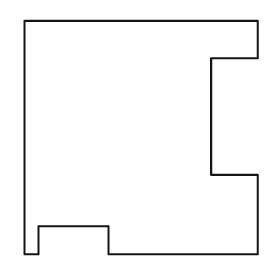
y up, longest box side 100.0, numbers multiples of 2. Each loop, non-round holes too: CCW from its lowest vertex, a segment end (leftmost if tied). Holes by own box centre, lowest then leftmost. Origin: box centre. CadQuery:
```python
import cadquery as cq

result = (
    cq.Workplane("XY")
    .moveTo(-50.0, -50.0)
    .lineTo(-44.0, -50.0)
    .lineTo(-44.0, -38.0)
    .lineTo(-14.0, -38.0)
    .lineTo(-14.0, -50.0)
    .lineTo(50.0, -50.0)
    .lineTo(50.0, -16.0)
    .lineTo(30.0, -16.0)
    .lineTo(30.0, 34.0)
    .lineTo(50.0, 34.0)
    .lineTo(50.0, 50.0)
    .lineTo(-50.0, 50.0)
    .close()
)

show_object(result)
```